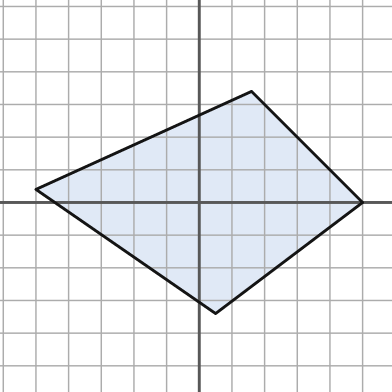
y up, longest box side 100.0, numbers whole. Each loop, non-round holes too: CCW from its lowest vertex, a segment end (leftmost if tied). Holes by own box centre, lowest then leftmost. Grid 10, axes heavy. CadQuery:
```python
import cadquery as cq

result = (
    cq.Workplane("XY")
    .moveTo(5.0, -34.0)
    .lineTo(50.0, 0.0)
    .lineTo(16.0, 34.0)
    .lineTo(-50.0, 4.0)
    .close()
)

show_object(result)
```